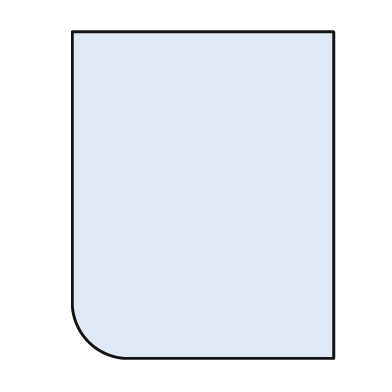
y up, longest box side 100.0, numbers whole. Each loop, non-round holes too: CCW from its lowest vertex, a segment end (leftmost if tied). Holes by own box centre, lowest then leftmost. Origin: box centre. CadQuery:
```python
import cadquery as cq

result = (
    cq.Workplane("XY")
    .moveTo(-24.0, -50.0)
    .lineTo(40.0, -50.0)
    .lineTo(40.0, 50.0)
    .lineTo(-40.0, 50.0)
    .lineTo(-40.0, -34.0)
    .threePointArc((-35.0, -45.0), (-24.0, -50.0))
    .close()
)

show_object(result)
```